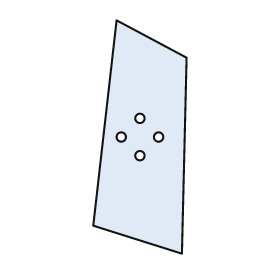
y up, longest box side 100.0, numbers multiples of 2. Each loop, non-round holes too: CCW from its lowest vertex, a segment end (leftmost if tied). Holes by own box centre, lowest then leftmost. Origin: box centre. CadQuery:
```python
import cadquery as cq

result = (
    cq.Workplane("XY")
    .moveTo(18.0, -50.0)
    .lineTo(20.0, 34.0)
    .lineTo(-10.0, 50.0)
    .lineTo(-20.0, -38.0)
    .close()
    .moveTo(0.0, -8.0)
    .circle(2.0)
    .moveTo(-8.0, 0.0)
    .circle(2.0)
    .moveTo(8.0, 0.0)
    .circle(2.0)
    .moveTo(0.0, 8.0)
    .circle(2.0)
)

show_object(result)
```